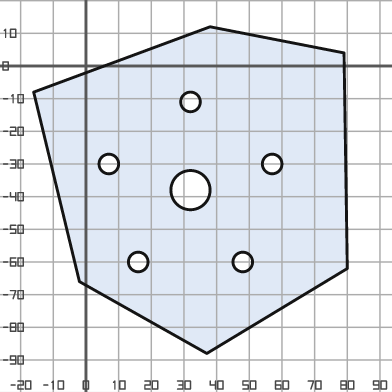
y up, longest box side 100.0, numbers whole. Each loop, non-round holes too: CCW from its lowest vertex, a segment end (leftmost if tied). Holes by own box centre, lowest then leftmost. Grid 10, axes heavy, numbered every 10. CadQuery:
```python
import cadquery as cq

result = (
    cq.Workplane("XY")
    .moveTo(37.0, -88.0)
    .lineTo(80.0, -62.0)
    .lineTo(79.0, 4.0)
    .lineTo(38.0, 12.0)
    .lineTo(-16.0, -8.0)
    .lineTo(-2.0, -66.0)
    .close()
    .moveTo(16.0, -60.0)
    .circle(3.0)
    .moveTo(48.0, -60.0)
    .circle(3.0)
    .moveTo(32.0, -38.0)
    .circle(6.0)
    .moveTo(7.0, -30.0)
    .circle(3.0)
    .moveTo(57.0, -30.0)
    .circle(3.0)
    .moveTo(32.0, -11.0)
    .circle(3.0)
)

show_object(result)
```